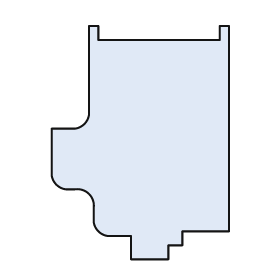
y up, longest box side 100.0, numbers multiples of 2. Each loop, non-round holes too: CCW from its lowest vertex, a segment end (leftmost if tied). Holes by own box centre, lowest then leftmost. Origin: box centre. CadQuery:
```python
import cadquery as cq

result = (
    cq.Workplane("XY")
    .moveTo(-4.0, -50.0)
    .lineTo(12.0, -50.0)
    .lineTo(12.0, -44.0)
    .lineTo(18.0, -44.0)
    .lineTo(18.0, -38.0)
    .lineTo(38.0, -38.0)
    .lineTo(38.0, 50.0)
    .lineTo(34.0, 50.0)
    .lineTo(34.0, 44.0)
    .lineTo(-18.0, 44.0)
    .lineTo(-18.0, 50.0)
    .lineTo(-22.0, 50.0)
    .lineTo(-22.0, 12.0)
    .threePointArc((-24.0, 8.0), (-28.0, 6.0))
    .lineTo(-38.0, 6.0)
    .lineTo(-38.0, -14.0)
    .threePointArc((-36.0, -18.0), (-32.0, -20.0))
    .lineTo(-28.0, -20.0)
    .threePointArc((-22.0, -22.0), (-20.0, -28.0))
    .lineTo(-20.0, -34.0)
    .threePointArc((-18.0, -38.0), (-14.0, -40.0))
    .lineTo(-4.0, -40.0)
    .close()
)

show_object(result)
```